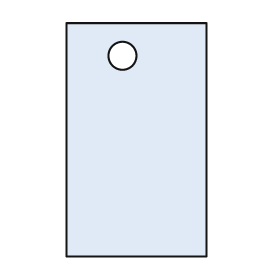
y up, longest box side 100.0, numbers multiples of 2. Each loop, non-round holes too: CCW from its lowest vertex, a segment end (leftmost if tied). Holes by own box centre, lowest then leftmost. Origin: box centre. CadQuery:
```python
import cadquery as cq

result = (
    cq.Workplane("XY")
    .moveTo(-30.0, -50.0)
    .lineTo(30.0, -50.0)
    .lineTo(30.0, 50.0)
    .lineTo(-30.0, 50.0)
    .close()
    .moveTo(-6.0, 36.0)
    .circle(6.0)
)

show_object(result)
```